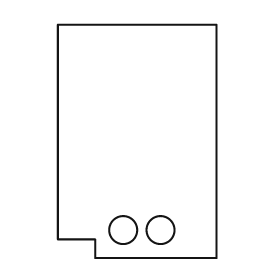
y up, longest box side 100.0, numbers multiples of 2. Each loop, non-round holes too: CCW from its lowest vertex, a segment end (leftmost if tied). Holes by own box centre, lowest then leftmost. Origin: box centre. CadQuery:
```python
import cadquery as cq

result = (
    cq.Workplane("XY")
    .moveTo(-18.0, -50.0)
    .lineTo(34.0, -50.0)
    .lineTo(34.0, 50.0)
    .lineTo(-34.0, 50.0)
    .lineTo(-34.0, -42.0)
    .lineTo(-18.0, -42.0)
    .close()
    .moveTo(-6.0, -38.0)
    .circle(6.0)
    .moveTo(10.0, -38.0)
    .circle(6.0)
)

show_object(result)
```